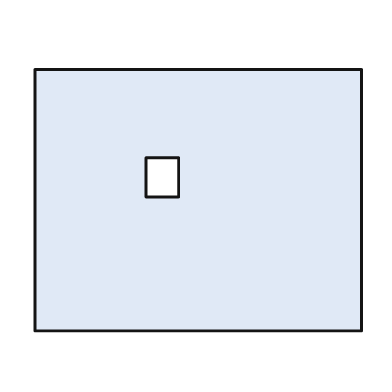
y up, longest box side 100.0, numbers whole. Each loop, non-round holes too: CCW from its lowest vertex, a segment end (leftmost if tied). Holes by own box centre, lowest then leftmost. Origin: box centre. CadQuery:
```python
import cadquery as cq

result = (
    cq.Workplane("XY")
    .moveTo(-50.0, -40.0)
    .lineTo(50.0, -40.0)
    .lineTo(50.0, 40.0)
    .lineTo(-50.0, 40.0)
    .close()
    .moveTo(-16.0, 1.0)
    .lineTo(-6.0, 1.0)
    .lineTo(-6.0, 13.0)
    .lineTo(-16.0, 13.0)
    .close()
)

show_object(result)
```